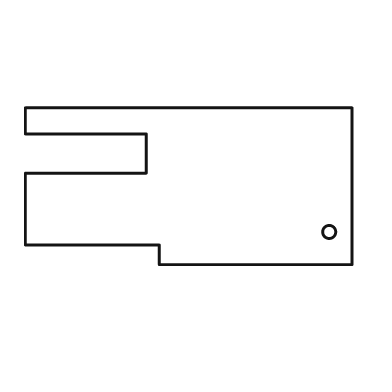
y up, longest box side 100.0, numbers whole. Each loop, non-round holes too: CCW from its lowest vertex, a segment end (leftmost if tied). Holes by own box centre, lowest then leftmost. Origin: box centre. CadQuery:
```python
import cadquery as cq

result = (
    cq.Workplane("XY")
    .moveTo(-9.0, -24.0)
    .lineTo(50.0, -24.0)
    .lineTo(50.0, 24.0)
    .lineTo(-50.0, 24.0)
    .lineTo(-50.0, 16.0)
    .lineTo(-13.0, 16.0)
    .lineTo(-13.0, 4.0)
    .lineTo(-50.0, 4.0)
    .lineTo(-50.0, -18.0)
    .lineTo(-9.0, -18.0)
    .close()
    .moveTo(43.0, -14.0)
    .circle(2.0)
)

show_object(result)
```